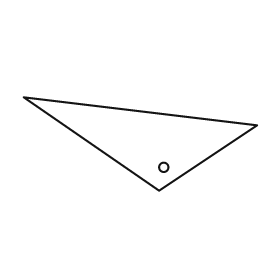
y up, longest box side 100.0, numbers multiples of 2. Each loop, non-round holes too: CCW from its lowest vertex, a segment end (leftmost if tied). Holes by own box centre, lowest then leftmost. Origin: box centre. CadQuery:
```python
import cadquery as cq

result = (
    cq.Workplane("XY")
    .moveTo(8.0, -20.0)
    .lineTo(50.0, 8.0)
    .lineTo(-50.0, 20.0)
    .close()
    .moveTo(10.0, -10.0)
    .circle(2.0)
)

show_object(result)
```